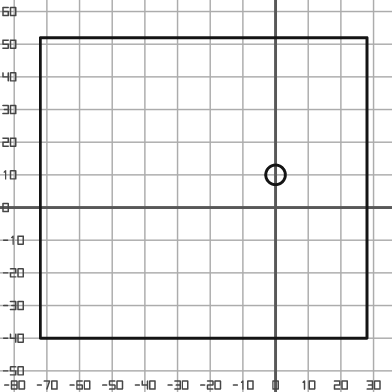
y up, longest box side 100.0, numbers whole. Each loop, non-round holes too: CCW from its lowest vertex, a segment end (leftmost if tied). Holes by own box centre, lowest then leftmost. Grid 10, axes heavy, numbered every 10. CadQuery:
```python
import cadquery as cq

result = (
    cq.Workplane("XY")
    .moveTo(-72.0, -40.0)
    .lineTo(28.0, -40.0)
    .lineTo(28.0, 52.0)
    .lineTo(-72.0, 52.0)
    .close()
    .moveTo(0.0, 10.0)
    .circle(3.0)
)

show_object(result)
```